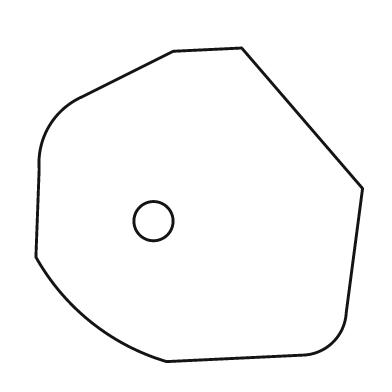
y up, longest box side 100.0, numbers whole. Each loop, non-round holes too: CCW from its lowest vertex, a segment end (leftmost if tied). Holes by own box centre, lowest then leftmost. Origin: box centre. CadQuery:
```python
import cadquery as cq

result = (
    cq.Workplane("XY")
    .moveTo(-10.0, -48.0)
    .lineTo(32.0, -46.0)
    .threePointArc((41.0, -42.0), (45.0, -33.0))
    .lineTo(50.0, 5.0)
    .lineTo(13.0, 48.0)
    .lineTo(-8.0, 47.0)
    .lineTo(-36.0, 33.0)
    .threePointArc((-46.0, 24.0), (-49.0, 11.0))
    .lineTo(-50.0, -16.0)
    .threePointArc((-33.0, -36.0), (-10.0, -48.0))
    .close()
    .moveTo(-14.0, -5.0)
    .circle(6.0)
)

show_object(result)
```